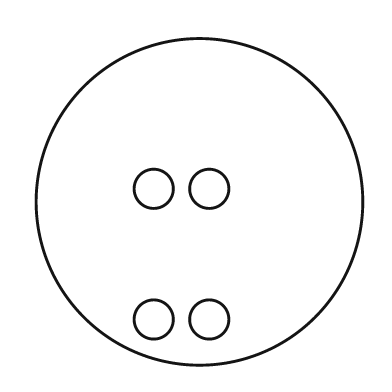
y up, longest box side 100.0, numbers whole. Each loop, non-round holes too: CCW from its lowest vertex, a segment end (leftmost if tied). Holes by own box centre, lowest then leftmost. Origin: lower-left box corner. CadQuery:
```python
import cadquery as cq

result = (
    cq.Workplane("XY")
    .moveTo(50.0, 50.0)
    .circle(50.0)
    .moveTo(36.0, 14.0)
    .circle(6.0)
    .moveTo(53.0, 14.0)
    .circle(6.0)
    .moveTo(36.0, 54.0)
    .circle(6.0)
    .moveTo(53.0, 54.0)
    .circle(6.0)
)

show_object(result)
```